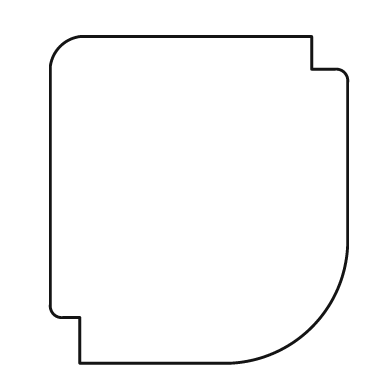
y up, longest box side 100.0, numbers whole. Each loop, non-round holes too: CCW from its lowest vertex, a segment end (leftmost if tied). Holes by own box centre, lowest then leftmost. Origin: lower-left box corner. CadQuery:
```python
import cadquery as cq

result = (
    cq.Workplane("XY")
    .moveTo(9.0, 0.0)
    .lineTo(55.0, 0.0)
    .threePointArc((80.0, 11.0), (91.0, 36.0))
    .lineTo(91.0, 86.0)
    .threePointArc((90.0, 89.0), (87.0, 90.0))
    .lineTo(80.0, 90.0)
    .lineTo(80.0, 100.0)
    .lineTo(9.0, 100.0)
    .threePointArc((3.0, 97.0), (0.0, 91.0))
    .lineTo(0.0, 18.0)
    .threePointArc((1.0, 15.0), (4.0, 14.0))
    .lineTo(9.0, 14.0)
    .close()
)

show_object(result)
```